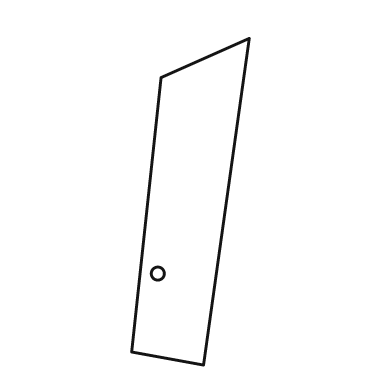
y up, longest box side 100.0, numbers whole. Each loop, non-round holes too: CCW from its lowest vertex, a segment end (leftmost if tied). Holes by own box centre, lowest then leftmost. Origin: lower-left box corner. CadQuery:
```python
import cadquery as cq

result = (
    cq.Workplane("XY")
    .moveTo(22.0, 0.0)
    .lineTo(36.0, 100.0)
    .lineTo(9.0, 88.0)
    .lineTo(0.0, 4.0)
    .close()
    .moveTo(8.0, 28.0)
    .circle(2.0)
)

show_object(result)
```